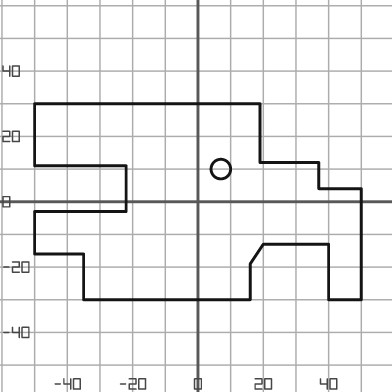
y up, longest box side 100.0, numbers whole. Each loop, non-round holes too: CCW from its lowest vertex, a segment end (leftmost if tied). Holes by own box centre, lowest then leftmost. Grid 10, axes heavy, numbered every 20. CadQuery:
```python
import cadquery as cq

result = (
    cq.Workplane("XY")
    .moveTo(-35.0, -30.0)
    .lineTo(16.0, -30.0)
    .lineTo(16.0, -19.0)
    .lineTo(20.0, -13.0)
    .lineTo(40.0, -13.0)
    .lineTo(40.0, -30.0)
    .lineTo(50.0, -30.0)
    .lineTo(50.0, 4.0)
    .lineTo(37.0, 4.0)
    .lineTo(37.0, 12.0)
    .lineTo(19.0, 12.0)
    .lineTo(19.0, 30.0)
    .lineTo(-50.0, 30.0)
    .lineTo(-50.0, 11.0)
    .lineTo(-22.0, 11.0)
    .lineTo(-22.0, -3.0)
    .lineTo(-50.0, -3.0)
    .lineTo(-50.0, -16.0)
    .lineTo(-35.0, -16.0)
    .close()
    .moveTo(7.0, 10.0)
    .circle(3.0)
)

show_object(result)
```